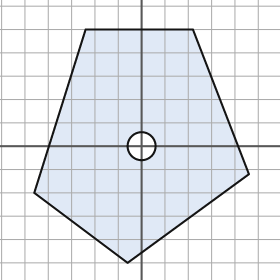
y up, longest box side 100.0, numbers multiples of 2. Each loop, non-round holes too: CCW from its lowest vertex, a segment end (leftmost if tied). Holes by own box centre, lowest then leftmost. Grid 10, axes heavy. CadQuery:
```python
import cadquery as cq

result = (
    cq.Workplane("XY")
    .moveTo(-6.0, -50.0)
    .lineTo(46.0, -12.0)
    .lineTo(22.0, 50.0)
    .lineTo(-24.0, 50.0)
    .lineTo(-46.0, -20.0)
    .close()
    .moveTo(0.0, 0.0)
    .circle(6.0)
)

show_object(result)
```